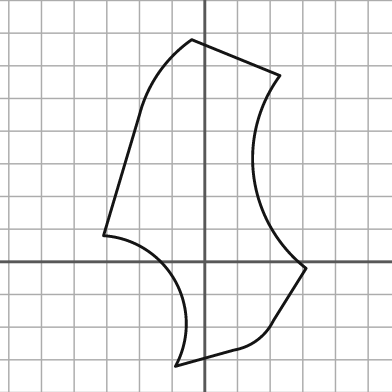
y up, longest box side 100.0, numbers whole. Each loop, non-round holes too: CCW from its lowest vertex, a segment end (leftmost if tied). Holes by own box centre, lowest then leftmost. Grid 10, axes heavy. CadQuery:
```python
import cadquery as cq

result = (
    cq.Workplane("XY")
    .moveTo(-9.0, -32.0)
    .lineTo(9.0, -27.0)
    .threePointArc((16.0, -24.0), (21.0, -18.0))
    .lineTo(31.0, -2.0)
    .threePointArc((15.0, 26.0), (23.0, 57.0))
    .lineTo(-4.0, 68.0)
    .threePointArc((-14.0, 58.0), (-20.0, 45.0))
    .lineTo(-31.0, 8.0)
    .threePointArc((-9.0, -6.0), (-9.0, -32.0))
    .close()
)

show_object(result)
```